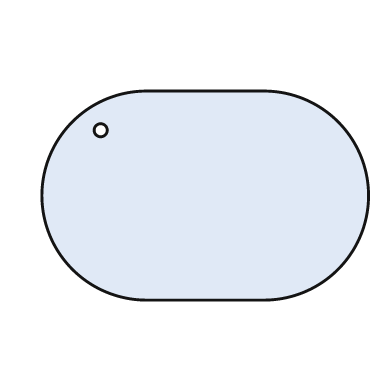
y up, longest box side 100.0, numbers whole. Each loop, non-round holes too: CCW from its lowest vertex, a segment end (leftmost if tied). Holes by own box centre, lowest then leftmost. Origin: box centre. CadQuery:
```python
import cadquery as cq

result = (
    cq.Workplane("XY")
    .moveTo(-18.0, -32.0)
    .lineTo(18.0, -32.0)
    .threePointArc((50.0, 0.0), (18.0, 32.0))
    .lineTo(-18.0, 32.0)
    .threePointArc((-50.0, 0.0), (-18.0, -32.0))
    .close()
    .moveTo(-32.0, 20.0)
    .circle(2.0)
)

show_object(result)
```